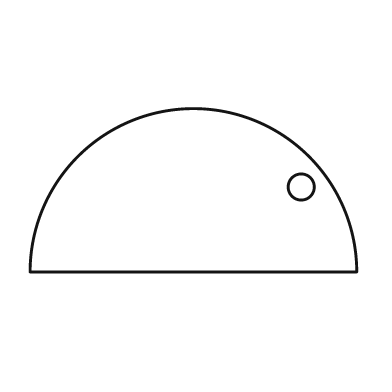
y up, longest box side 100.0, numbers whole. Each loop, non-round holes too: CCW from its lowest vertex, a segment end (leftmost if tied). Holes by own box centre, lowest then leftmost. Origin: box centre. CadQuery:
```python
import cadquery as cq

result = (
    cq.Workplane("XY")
    .moveTo(-50.0, -25.0)
    .lineTo(50.0, -25.0)
    .threePointArc((0.0, 25.0), (-50.0, -25.0))
    .close()
    .moveTo(33.0, 1.0)
    .circle(4.0)
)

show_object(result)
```